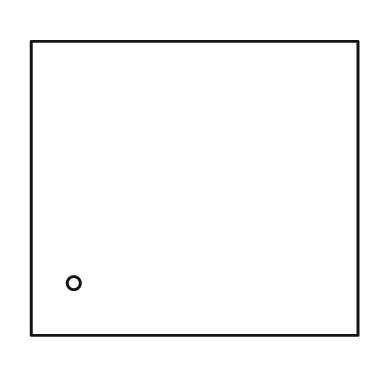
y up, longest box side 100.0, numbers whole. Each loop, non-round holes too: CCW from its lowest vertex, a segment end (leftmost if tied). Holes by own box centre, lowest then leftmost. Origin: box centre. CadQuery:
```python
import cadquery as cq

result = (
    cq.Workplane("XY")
    .moveTo(-50.0, -45.0)
    .lineTo(50.0, -45.0)
    .lineTo(50.0, 45.0)
    .lineTo(-50.0, 45.0)
    .close()
    .moveTo(-37.0, -29.0)
    .circle(2.0)
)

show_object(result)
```